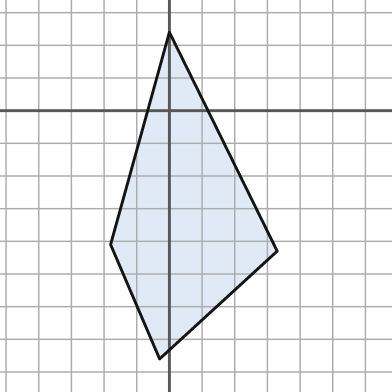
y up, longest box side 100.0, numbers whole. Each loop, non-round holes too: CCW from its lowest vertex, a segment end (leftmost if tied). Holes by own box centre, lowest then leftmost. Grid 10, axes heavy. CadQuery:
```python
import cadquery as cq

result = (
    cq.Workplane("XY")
    .moveTo(-3.0, -76.0)
    .lineTo(33.0, -43.0)
    .lineTo(0.0, 24.0)
    .lineTo(-18.0, -41.0)
    .close()
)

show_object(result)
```